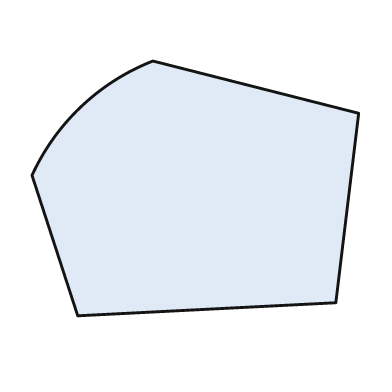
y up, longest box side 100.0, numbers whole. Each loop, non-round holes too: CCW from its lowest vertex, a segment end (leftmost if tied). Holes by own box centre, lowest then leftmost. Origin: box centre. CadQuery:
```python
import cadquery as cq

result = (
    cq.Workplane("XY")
    .moveTo(-36.0, -39.0)
    .lineTo(43.0, -35.0)
    .lineTo(50.0, 23.0)
    .lineTo(-13.0, 39.0)
    .threePointArc((-35.0, 25.0), (-50.0, 4.0))
    .close()
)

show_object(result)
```